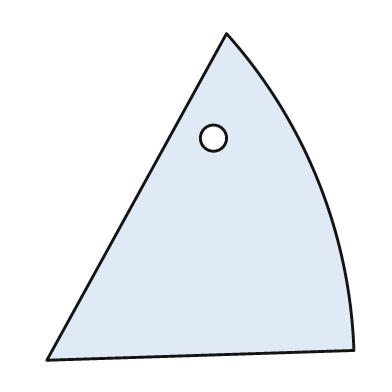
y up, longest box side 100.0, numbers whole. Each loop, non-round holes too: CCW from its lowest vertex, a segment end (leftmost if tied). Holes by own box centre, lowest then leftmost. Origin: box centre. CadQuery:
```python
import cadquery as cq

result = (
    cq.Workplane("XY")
    .moveTo(-47.0, -50.0)
    .lineTo(47.0, -47.0)
    .threePointArc((36.0, 5.0), (8.0, 50.0))
    .close()
    .moveTo(4.0, 18.0)
    .circle(4.0)
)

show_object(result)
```